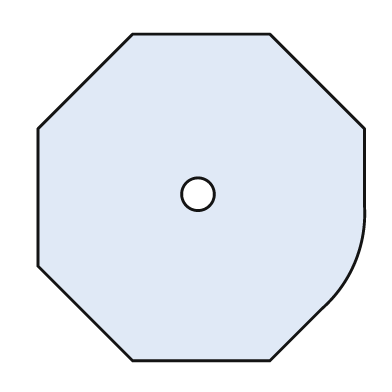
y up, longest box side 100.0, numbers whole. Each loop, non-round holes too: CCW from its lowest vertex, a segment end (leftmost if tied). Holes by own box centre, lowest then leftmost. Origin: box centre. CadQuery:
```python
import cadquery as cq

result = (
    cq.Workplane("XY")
    .moveTo(-21.0, -50.0)
    .lineTo(21.0, -50.0)
    .lineTo(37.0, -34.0)
    .threePointArc((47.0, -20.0), (50.0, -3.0))
    .lineTo(50.0, 21.0)
    .lineTo(21.0, 50.0)
    .lineTo(-21.0, 50.0)
    .lineTo(-50.0, 21.0)
    .lineTo(-50.0, -21.0)
    .close()
    .moveTo(-1.0, 1.0)
    .circle(5.0)
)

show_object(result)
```